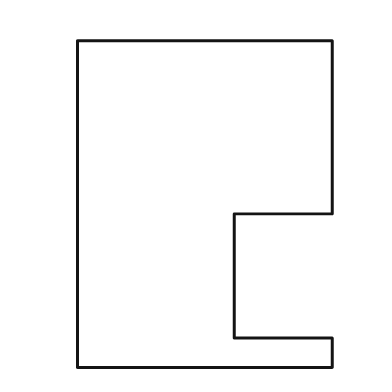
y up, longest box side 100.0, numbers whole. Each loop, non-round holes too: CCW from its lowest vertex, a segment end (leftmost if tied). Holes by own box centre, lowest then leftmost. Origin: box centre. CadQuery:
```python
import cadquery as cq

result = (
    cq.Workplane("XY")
    .moveTo(-39.0, -50.0)
    .lineTo(39.0, -50.0)
    .lineTo(39.0, -41.0)
    .lineTo(9.0, -41.0)
    .lineTo(9.0, -3.0)
    .lineTo(39.0, -3.0)
    .lineTo(39.0, 50.0)
    .lineTo(-39.0, 50.0)
    .close()
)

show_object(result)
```